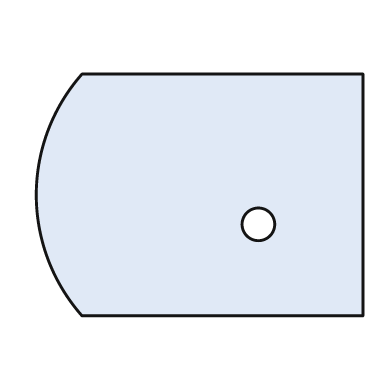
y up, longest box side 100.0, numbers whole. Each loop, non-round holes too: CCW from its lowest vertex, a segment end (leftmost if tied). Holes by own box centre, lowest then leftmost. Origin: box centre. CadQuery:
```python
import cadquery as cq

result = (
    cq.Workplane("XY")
    .moveTo(-36.0, -37.0)
    .lineTo(50.0, -37.0)
    .lineTo(50.0, 37.0)
    .lineTo(-36.0, 37.0)
    .threePointArc((-50.0, 0.0), (-36.0, -37.0))
    .close()
    .moveTo(18.0, -9.0)
    .circle(5.0)
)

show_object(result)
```